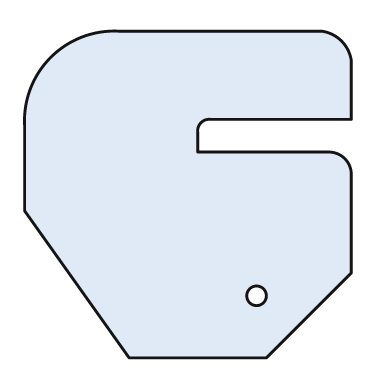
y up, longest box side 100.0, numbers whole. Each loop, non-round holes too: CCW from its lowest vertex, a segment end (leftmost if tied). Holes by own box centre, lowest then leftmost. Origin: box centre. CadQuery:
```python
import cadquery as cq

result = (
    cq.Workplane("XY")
    .moveTo(-18.0, -50.0)
    .lineTo(24.0, -50.0)
    .lineTo(50.0, -24.0)
    .lineTo(50.0, 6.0)
    .threePointArc((48.0, 11.0), (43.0, 13.0))
    .lineTo(3.0, 13.0)
    .lineTo(3.0, 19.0)
    .threePointArc((4.0, 22.0), (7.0, 23.0))
    .lineTo(50.0, 23.0)
    .lineTo(50.0, 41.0)
    .threePointArc((47.0, 47.0), (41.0, 50.0))
    .lineTo(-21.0, 50.0)
    .threePointArc((-42.0, 42.0), (-50.0, 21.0))
    .lineTo(-50.0, -5.0)
    .close()
    .moveTo(21.0, -31.0)
    .circle(3.0)
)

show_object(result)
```